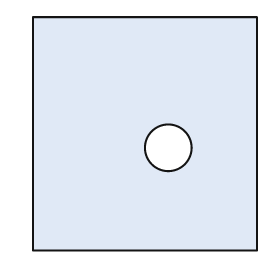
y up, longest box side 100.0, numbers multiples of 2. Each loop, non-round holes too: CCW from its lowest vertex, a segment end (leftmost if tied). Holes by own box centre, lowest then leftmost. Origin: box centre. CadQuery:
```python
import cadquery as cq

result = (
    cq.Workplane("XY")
    .moveTo(-48.0, -50.0)
    .lineTo(48.0, -50.0)
    .lineTo(48.0, 50.0)
    .lineTo(-48.0, 50.0)
    .close()
    .moveTo(10.0, -6.0)
    .circle(10.0)
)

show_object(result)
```